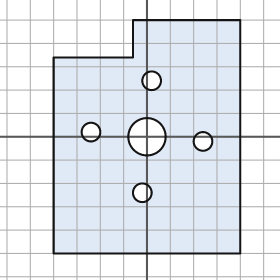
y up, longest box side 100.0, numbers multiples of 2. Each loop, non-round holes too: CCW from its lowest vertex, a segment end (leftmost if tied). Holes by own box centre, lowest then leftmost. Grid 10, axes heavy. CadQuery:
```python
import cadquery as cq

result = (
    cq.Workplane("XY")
    .moveTo(-40.0, -50.0)
    .lineTo(40.0, -50.0)
    .lineTo(40.0, 50.0)
    .lineTo(-6.0, 50.0)
    .lineTo(-6.0, 34.0)
    .lineTo(-40.0, 34.0)
    .close()
    .moveTo(-2.0, -24.0)
    .circle(4.0)
    .moveTo(24.0, -2.0)
    .circle(4.0)
    .moveTo(0.0, 0.0)
    .circle(8.0)
    .moveTo(-24.0, 2.0)
    .circle(4.0)
    .moveTo(2.0, 24.0)
    .circle(4.0)
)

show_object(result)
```